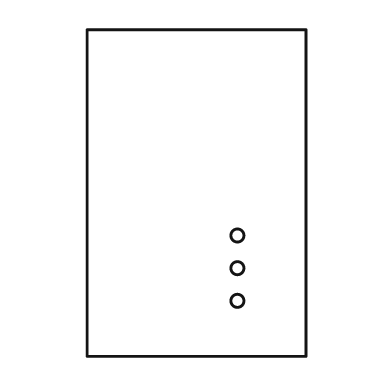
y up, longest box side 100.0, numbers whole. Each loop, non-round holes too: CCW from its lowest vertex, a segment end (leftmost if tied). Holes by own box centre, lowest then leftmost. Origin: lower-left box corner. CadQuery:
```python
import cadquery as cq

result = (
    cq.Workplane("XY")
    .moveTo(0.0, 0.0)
    .lineTo(67.0, 0.0)
    .lineTo(67.0, 100.0)
    .lineTo(0.0, 100.0)
    .close()
    .moveTo(46.0, 17.0)
    .circle(2.0)
    .moveTo(46.0, 27.0)
    .circle(2.0)
    .moveTo(46.0, 37.0)
    .circle(2.0)
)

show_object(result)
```